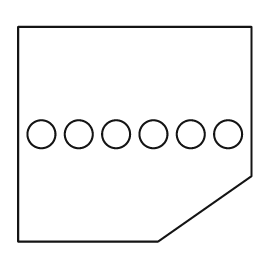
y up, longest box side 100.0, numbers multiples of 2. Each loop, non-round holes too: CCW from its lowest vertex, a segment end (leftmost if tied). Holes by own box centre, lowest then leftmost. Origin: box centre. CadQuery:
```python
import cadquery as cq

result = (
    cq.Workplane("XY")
    .moveTo(-50.0, -46.0)
    .lineTo(10.0, -46.0)
    .lineTo(50.0, -18.0)
    .lineTo(50.0, 46.0)
    .lineTo(-50.0, 46.0)
    .close()
    .moveTo(-40.0, 0.0)
    .circle(6.0)
    .moveTo(-24.0, 0.0)
    .circle(6.0)
    .moveTo(-8.0, 0.0)
    .circle(6.0)
    .moveTo(8.0, 0.0)
    .circle(6.0)
    .moveTo(24.0, 0.0)
    .circle(6.0)
    .moveTo(40.0, 0.0)
    .circle(6.0)
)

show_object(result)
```